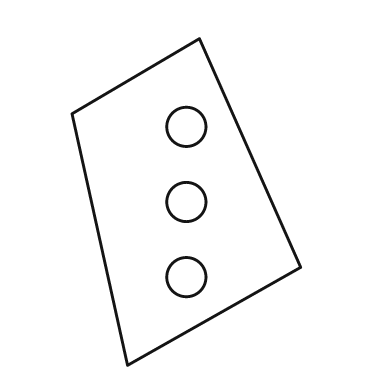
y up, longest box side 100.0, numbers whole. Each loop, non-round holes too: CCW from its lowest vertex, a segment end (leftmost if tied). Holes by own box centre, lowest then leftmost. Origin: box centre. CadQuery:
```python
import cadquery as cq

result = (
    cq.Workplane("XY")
    .moveTo(-18.0, -50.0)
    .lineTo(35.0, -20.0)
    .lineTo(4.0, 50.0)
    .lineTo(-35.0, 27.0)
    .close()
    .moveTo(0.0, -23.0)
    .circle(6.0)
    .moveTo(0.0, 0.0)
    .circle(6.0)
    .moveTo(0.0, 23.0)
    .circle(6.0)
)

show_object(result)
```